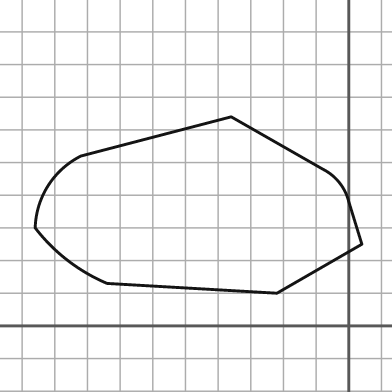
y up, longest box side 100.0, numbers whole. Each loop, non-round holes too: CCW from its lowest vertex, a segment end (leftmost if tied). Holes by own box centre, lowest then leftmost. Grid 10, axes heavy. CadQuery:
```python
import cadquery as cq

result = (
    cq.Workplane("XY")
    .moveTo(-22.0, 10.0)
    .lineTo(4.0, 25.0)
    .lineTo(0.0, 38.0)
    .threePointArc((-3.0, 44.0), (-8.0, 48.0))
    .lineTo(-36.0, 64.0)
    .lineTo(-82.0, 52.0)
    .threePointArc((-92.0, 43.0), (-96.0, 30.0))
    .threePointArc((-86.0, 20.0), (-74.0, 13.0))
    .close()
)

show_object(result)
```